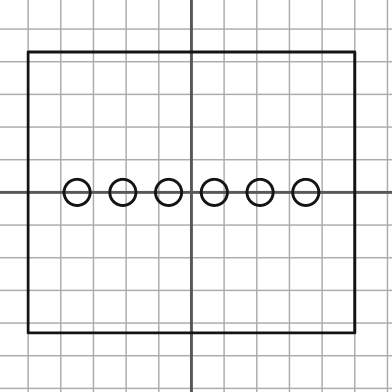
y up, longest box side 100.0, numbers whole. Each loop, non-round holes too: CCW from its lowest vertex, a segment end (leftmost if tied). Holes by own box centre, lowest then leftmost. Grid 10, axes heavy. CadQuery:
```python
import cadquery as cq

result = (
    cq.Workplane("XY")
    .moveTo(-50.0, -43.0)
    .lineTo(50.0, -43.0)
    .lineTo(50.0, 43.0)
    .lineTo(-50.0, 43.0)
    .close()
    .moveTo(-35.0, 0.0)
    .circle(4.0)
    .moveTo(-21.0, 0.0)
    .circle(4.0)
    .moveTo(-7.0, 0.0)
    .circle(4.0)
    .moveTo(7.0, 0.0)
    .circle(4.0)
    .moveTo(21.0, 0.0)
    .circle(4.0)
    .moveTo(35.0, 0.0)
    .circle(4.0)
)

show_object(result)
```